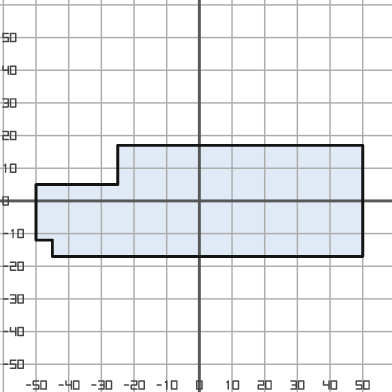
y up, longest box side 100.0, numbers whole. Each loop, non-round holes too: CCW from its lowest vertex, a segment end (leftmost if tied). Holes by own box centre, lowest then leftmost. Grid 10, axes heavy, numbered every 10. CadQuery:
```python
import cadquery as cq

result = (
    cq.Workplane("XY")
    .moveTo(-45.0, -17.0)
    .lineTo(50.0, -17.0)
    .lineTo(50.0, 17.0)
    .lineTo(-25.0, 17.0)
    .lineTo(-25.0, 5.0)
    .lineTo(-50.0, 5.0)
    .lineTo(-50.0, -12.0)
    .lineTo(-45.0, -12.0)
    .close()
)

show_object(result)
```